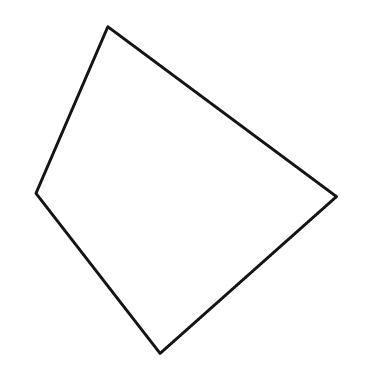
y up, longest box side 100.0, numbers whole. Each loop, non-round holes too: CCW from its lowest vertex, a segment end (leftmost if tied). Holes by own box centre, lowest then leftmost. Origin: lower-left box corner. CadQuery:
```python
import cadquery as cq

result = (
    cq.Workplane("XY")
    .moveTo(38.0, 0.0)
    .lineTo(92.0, 48.0)
    .lineTo(22.0, 100.0)
    .lineTo(0.0, 49.0)
    .close()
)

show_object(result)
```